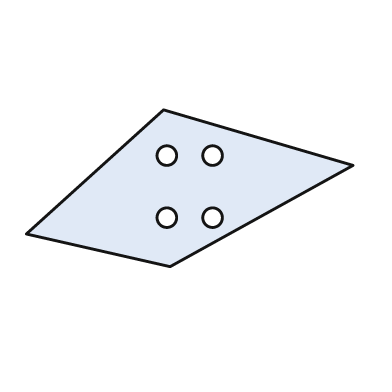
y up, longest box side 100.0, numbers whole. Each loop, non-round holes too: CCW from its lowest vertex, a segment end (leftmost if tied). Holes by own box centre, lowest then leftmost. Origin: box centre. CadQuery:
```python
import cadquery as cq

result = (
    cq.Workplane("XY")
    .moveTo(-6.0, -24.0)
    .lineTo(50.0, 7.0)
    .lineTo(-8.0, 24.0)
    .lineTo(-50.0, -14.0)
    .close()
    .moveTo(-7.0, -9.0)
    .circle(3.0)
    .moveTo(7.0, -9.0)
    .circle(3.0)
    .moveTo(-7.0, 10.0)
    .circle(3.0)
    .moveTo(7.0, 10.0)
    .circle(3.0)
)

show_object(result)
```